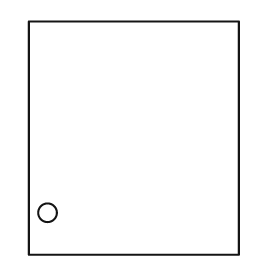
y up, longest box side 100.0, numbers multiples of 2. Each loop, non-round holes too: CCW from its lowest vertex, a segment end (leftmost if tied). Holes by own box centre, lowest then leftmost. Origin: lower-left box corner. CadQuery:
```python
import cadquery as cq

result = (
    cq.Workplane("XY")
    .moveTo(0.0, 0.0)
    .lineTo(90.0, 0.0)
    .lineTo(90.0, 100.0)
    .lineTo(0.0, 100.0)
    .close()
    .moveTo(8.0, 18.0)
    .circle(4.0)
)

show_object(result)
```